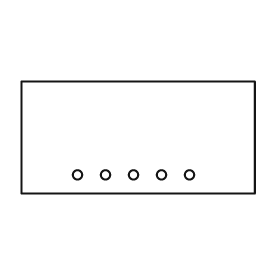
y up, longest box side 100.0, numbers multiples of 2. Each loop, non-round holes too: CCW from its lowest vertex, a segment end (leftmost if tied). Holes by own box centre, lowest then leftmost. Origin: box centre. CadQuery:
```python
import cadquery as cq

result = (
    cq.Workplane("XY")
    .moveTo(-50.0, -24.0)
    .lineTo(50.0, -24.0)
    .lineTo(50.0, 24.0)
    .lineTo(-50.0, 24.0)
    .close()
    .moveTo(-26.0, -16.0)
    .circle(2.0)
    .moveTo(-14.0, -16.0)
    .circle(2.0)
    .moveTo(-2.0, -16.0)
    .circle(2.0)
    .moveTo(10.0, -16.0)
    .circle(2.0)
    .moveTo(22.0, -16.0)
    .circle(2.0)
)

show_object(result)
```